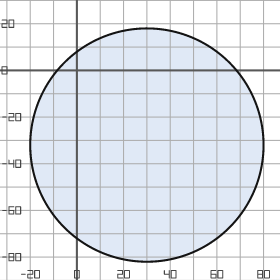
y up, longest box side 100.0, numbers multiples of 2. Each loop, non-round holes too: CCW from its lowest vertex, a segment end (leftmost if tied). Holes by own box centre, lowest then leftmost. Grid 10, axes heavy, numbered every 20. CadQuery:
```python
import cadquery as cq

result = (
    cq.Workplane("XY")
    .moveTo(30.0, -32.0)
    .circle(50.0)
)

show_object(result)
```